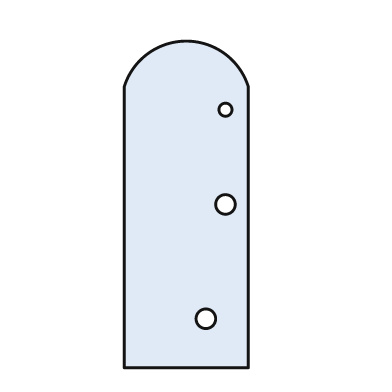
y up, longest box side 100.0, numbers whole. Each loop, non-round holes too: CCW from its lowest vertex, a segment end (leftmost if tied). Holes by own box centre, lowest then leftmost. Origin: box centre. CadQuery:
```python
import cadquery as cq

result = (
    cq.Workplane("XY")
    .moveTo(-19.0, -50.0)
    .lineTo(19.0, -50.0)
    .lineTo(19.0, 36.0)
    .threePointArc((0.0, 50.0), (-19.0, 36.0))
    .close()
    .moveTo(6.0, -35.0)
    .circle(3.0)
    .moveTo(12.0, 0.0)
    .circle(3.0)
    .moveTo(12.0, 29.0)
    .circle(2.0)
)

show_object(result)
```